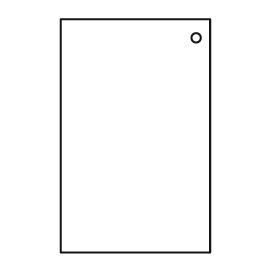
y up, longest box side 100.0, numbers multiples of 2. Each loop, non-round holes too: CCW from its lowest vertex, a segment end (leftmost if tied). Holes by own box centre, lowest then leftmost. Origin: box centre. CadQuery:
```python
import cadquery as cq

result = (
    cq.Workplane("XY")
    .moveTo(-32.0, -50.0)
    .lineTo(32.0, -50.0)
    .lineTo(32.0, 50.0)
    .lineTo(-32.0, 50.0)
    .close()
    .moveTo(26.0, 42.0)
    .circle(2.0)
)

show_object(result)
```